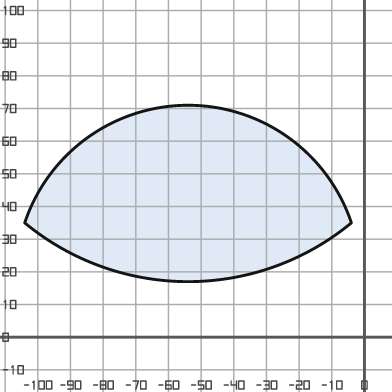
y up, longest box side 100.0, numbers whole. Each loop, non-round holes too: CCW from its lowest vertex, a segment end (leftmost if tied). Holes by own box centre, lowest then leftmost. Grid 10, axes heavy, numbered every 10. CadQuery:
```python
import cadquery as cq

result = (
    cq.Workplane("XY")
    .moveTo(-104.0, 35.0)
    .threePointArc((-54.0, 17.0), (-4.0, 35.0))
    .threePointArc((-54.0, 71.0), (-104.0, 35.0))
    .close()
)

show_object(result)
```